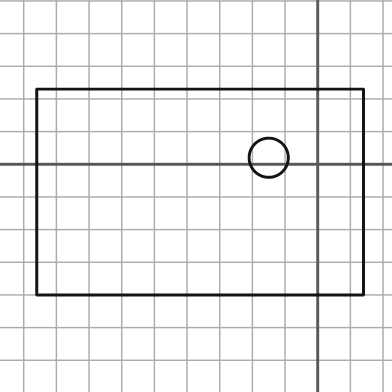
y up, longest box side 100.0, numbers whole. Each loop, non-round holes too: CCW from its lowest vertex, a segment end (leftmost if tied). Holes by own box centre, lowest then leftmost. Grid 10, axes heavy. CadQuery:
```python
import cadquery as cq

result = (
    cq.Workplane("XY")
    .moveTo(-86.0, -40.0)
    .lineTo(14.0, -40.0)
    .lineTo(14.0, 23.0)
    .lineTo(-86.0, 23.0)
    .close()
    .moveTo(-15.0, 2.0)
    .circle(6.0)
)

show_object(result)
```